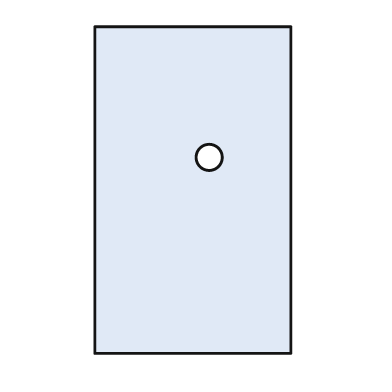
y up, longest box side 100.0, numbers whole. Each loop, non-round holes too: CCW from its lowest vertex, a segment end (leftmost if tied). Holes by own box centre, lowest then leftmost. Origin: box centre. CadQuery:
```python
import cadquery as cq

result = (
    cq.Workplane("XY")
    .moveTo(-30.0, -50.0)
    .lineTo(30.0, -50.0)
    .lineTo(30.0, 50.0)
    .lineTo(-30.0, 50.0)
    .close()
    .moveTo(5.0, 10.0)
    .circle(4.0)
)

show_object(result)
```